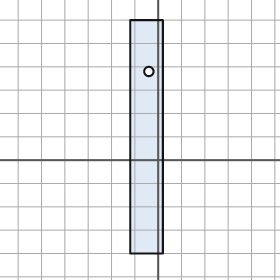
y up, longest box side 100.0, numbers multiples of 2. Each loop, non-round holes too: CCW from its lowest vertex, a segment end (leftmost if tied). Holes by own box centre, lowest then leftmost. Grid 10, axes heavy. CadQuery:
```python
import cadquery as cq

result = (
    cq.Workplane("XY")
    .moveTo(-12.0, -40.0)
    .lineTo(2.0, -40.0)
    .lineTo(2.0, 60.0)
    .lineTo(-12.0, 60.0)
    .close()
    .moveTo(-4.0, 38.0)
    .circle(2.0)
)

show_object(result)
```